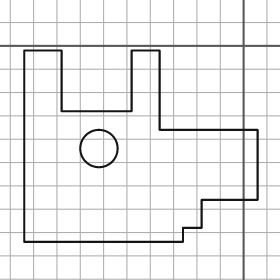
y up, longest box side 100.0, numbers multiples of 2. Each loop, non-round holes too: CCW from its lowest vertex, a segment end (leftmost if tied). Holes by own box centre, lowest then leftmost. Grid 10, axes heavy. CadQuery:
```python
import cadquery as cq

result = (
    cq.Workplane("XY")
    .moveTo(-94.0, -84.0)
    .lineTo(-26.0, -84.0)
    .lineTo(-26.0, -78.0)
    .lineTo(-18.0, -78.0)
    .lineTo(-18.0, -66.0)
    .lineTo(6.0, -66.0)
    .lineTo(6.0, -36.0)
    .lineTo(-36.0, -36.0)
    .lineTo(-36.0, -2.0)
    .lineTo(-48.0, -2.0)
    .lineTo(-48.0, -28.0)
    .lineTo(-78.0, -28.0)
    .lineTo(-78.0, -2.0)
    .lineTo(-94.0, -2.0)
    .close()
    .moveTo(-62.0, -44.0)
    .circle(8.0)
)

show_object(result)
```